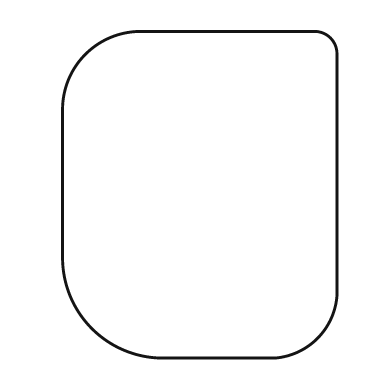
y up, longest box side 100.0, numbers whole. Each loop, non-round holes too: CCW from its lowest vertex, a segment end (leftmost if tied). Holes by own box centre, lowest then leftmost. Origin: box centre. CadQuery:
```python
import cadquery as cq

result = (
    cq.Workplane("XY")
    .moveTo(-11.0, -50.0)
    .lineTo(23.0, -50.0)
    .threePointArc((36.0, -44.0), (42.0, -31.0))
    .lineTo(42.0, 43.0)
    .threePointArc((40.0, 48.0), (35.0, 50.0))
    .lineTo(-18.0, 50.0)
    .threePointArc((-35.0, 43.0), (-42.0, 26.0))
    .lineTo(-42.0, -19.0)
    .threePointArc((-33.0, -41.0), (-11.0, -50.0))
    .close()
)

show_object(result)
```